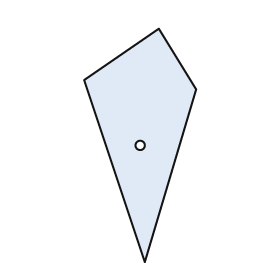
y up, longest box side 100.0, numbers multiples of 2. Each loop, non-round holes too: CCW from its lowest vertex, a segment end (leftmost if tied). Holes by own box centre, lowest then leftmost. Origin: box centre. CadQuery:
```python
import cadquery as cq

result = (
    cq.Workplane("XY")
    .moveTo(2.0, -50.0)
    .lineTo(24.0, 24.0)
    .lineTo(8.0, 50.0)
    .lineTo(-24.0, 28.0)
    .close()
    .moveTo(0.0, 0.0)
    .circle(2.0)
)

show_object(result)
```